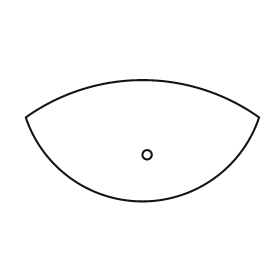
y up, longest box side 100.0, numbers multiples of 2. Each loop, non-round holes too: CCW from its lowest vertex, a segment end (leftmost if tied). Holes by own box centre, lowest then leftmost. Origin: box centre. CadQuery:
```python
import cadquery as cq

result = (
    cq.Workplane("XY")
    .moveTo(-50.0, 10.0)
    .threePointArc((0.0, -26.0), (50.0, 10.0))
    .threePointArc((0.0, 26.0), (-50.0, 10.0))
    .close()
    .moveTo(2.0, -6.0)
    .circle(2.0)
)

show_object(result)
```